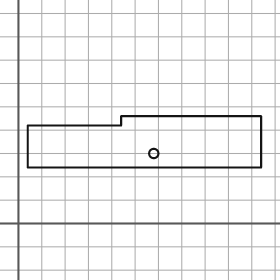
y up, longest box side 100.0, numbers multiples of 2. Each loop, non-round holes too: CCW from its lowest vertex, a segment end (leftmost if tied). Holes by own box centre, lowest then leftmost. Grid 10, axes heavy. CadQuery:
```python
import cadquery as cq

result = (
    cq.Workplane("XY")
    .moveTo(4.0, 24.0)
    .lineTo(104.0, 24.0)
    .lineTo(104.0, 46.0)
    .lineTo(44.0, 46.0)
    .lineTo(44.0, 42.0)
    .lineTo(4.0, 42.0)
    .close()
    .moveTo(58.0, 30.0)
    .circle(2.0)
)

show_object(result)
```